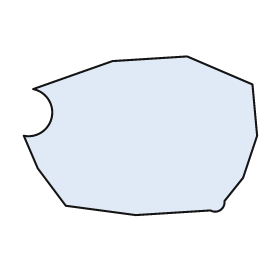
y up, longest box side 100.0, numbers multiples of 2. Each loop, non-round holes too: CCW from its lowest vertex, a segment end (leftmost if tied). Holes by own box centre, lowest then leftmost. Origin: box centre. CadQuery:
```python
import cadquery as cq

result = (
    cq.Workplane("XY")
    .moveTo(-2.0, -34.0)
    .lineTo(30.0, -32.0)
    .threePointArc((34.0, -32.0), (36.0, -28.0))
    .lineTo(44.0, -18.0)
    .lineTo(50.0, 0.0)
    .lineTo(48.0, 22.0)
    .lineTo(20.0, 34.0)
    .lineTo(-12.0, 32.0)
    .lineTo(-46.0, 20.0)
    .threePointArc((-38.0, 8.0), (-50.0, 0.0))
    .lineTo(-44.0, -14.0)
    .lineTo(-32.0, -30.0)
    .close()
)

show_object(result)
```